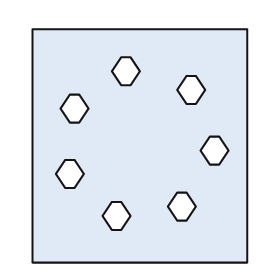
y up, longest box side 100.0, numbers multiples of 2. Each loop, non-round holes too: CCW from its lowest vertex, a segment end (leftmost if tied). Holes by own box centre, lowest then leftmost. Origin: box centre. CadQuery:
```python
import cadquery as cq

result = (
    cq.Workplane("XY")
    .moveTo(-46.0, -50.0)
    .lineTo(46.0, -50.0)
    .lineTo(46.0, 50.0)
    .lineTo(-46.0, 50.0)
    .close()
    .moveTo(-12.0, -36.0)
    .lineTo(-8.0, -36.0)
    .lineTo(-4.0, -30.0)
    .lineTo(-8.0, -24.0)
    .lineTo(-12.0, -24.0)
    .lineTo(-16.0, -30.0)
    .close()
    .moveTo(16.0, -32.0)
    .lineTo(20.0, -32.0)
    .lineTo(24.0, -26.0)
    .lineTo(20.0, -20.0)
    .lineTo(16.0, -20.0)
    .lineTo(12.0, -26.0)
    .close()
    .moveTo(-32.0, -18.0)
    .lineTo(-28.0, -18.0)
    .lineTo(-24.0, -12.0)
    .lineTo(-28.0, -6.0)
    .lineTo(-32.0, -6.0)
    .lineTo(-36.0, -12.0)
    .close()
    .moveTo(30.0, -8.0)
    .lineTo(34.0, -8.0)
    .lineTo(38.0, -2.0)
    .lineTo(34.0, 4.0)
    .lineTo(30.0, 4.0)
    .lineTo(26.0, -2.0)
    .close()
    .moveTo(-30.0, 10.0)
    .lineTo(-26.0, 10.0)
    .lineTo(-22.0, 16.0)
    .lineTo(-26.0, 22.0)
    .lineTo(-30.0, 22.0)
    .lineTo(-34.0, 16.0)
    .close()
    .moveTo(20.0, 18.0)
    .lineTo(24.0, 18.0)
    .lineTo(28.0, 24.0)
    .lineTo(24.0, 30.0)
    .lineTo(20.0, 30.0)
    .lineTo(16.0, 24.0)
    .close()
    .moveTo(-8.0, 26.0)
    .lineTo(-4.0, 26.0)
    .lineTo(0.0, 32.0)
    .lineTo(-4.0, 38.0)
    .lineTo(-8.0, 38.0)
    .lineTo(-12.0, 32.0)
    .close()
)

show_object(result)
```